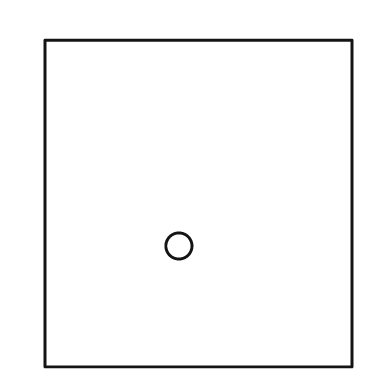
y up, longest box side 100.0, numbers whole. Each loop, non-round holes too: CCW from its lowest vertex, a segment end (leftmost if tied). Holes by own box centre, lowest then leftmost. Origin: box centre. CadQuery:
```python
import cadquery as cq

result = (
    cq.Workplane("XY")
    .moveTo(-47.0, -50.0)
    .lineTo(47.0, -50.0)
    .lineTo(47.0, 50.0)
    .lineTo(-47.0, 50.0)
    .close()
    .moveTo(-6.0, -13.0)
    .circle(4.0)
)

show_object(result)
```